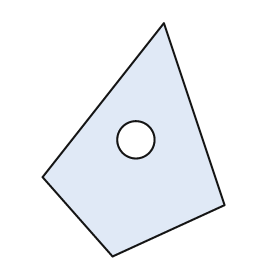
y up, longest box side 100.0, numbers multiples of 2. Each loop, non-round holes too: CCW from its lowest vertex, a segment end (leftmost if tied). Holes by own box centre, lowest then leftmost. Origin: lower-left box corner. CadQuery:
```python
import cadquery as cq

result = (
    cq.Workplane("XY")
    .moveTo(30.0, 0.0)
    .lineTo(78.0, 22.0)
    .lineTo(52.0, 100.0)
    .lineTo(0.0, 34.0)
    .close()
    .moveTo(40.0, 50.0)
    .circle(8.0)
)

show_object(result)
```